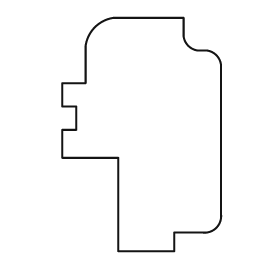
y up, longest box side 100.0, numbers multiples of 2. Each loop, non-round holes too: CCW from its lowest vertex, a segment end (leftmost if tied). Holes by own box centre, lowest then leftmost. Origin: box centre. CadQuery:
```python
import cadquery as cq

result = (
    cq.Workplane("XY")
    .moveTo(-10.0, -50.0)
    .lineTo(14.0, -50.0)
    .lineTo(14.0, -42.0)
    .lineTo(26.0, -42.0)
    .threePointArc((32.0, -40.0), (34.0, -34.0))
    .lineTo(34.0, 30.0)
    .threePointArc((32.0, 34.0), (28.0, 36.0))
    .lineTo(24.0, 36.0)
    .threePointArc((20.0, 38.0), (18.0, 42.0))
    .lineTo(18.0, 50.0)
    .lineTo(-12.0, 50.0)
    .threePointArc((-20.0, 46.0), (-24.0, 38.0))
    .lineTo(-24.0, 22.0)
    .lineTo(-34.0, 22.0)
    .lineTo(-34.0, 12.0)
    .lineTo(-28.0, 12.0)
    .lineTo(-28.0, 2.0)
    .lineTo(-34.0, 2.0)
    .lineTo(-34.0, -10.0)
    .lineTo(-10.0, -10.0)
    .close()
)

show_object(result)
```